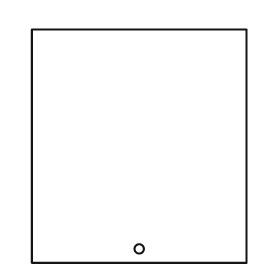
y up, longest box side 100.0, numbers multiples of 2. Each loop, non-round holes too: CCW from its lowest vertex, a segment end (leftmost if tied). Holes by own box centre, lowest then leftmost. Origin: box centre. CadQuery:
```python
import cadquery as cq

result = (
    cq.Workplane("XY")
    .moveTo(-46.0, -50.0)
    .lineTo(46.0, -50.0)
    .lineTo(46.0, 50.0)
    .lineTo(-46.0, 50.0)
    .close()
    .moveTo(0.0, -44.0)
    .circle(2.0)
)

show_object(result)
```